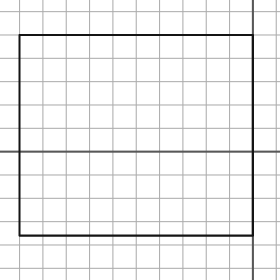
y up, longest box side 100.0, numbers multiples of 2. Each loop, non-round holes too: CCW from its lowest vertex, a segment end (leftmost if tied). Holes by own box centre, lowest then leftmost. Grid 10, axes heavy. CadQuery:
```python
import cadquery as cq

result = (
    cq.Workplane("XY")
    .moveTo(-100.0, -36.0)
    .lineTo(0.0, -36.0)
    .lineTo(0.0, 50.0)
    .lineTo(-100.0, 50.0)
    .close()
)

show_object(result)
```